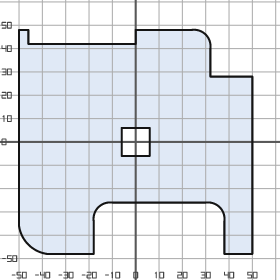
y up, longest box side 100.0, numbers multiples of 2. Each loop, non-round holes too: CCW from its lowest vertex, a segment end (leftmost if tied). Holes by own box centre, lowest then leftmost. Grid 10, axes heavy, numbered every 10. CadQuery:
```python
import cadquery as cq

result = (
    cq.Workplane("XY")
    .moveTo(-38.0, -48.0)
    .lineTo(-18.0, -48.0)
    .lineTo(-18.0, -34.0)
    .threePointArc((-16.0, -28.0), (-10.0, -26.0))
    .lineTo(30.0, -26.0)
    .threePointArc((36.0, -28.0), (38.0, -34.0))
    .lineTo(38.0, -48.0)
    .lineTo(50.0, -48.0)
    .lineTo(50.0, 28.0)
    .lineTo(32.0, 28.0)
    .lineTo(32.0, 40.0)
    .threePointArc((30.0, 46.0), (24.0, 48.0))
    .lineTo(0.0, 48.0)
    .lineTo(0.0, 42.0)
    .lineTo(-46.0, 42.0)
    .lineTo(-46.0, 48.0)
    .lineTo(-50.0, 48.0)
    .lineTo(-50.0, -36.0)
    .threePointArc((-46.0, -44.0), (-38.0, -48.0))
    .close()
    .moveTo(-6.0, -6.0)
    .lineTo(6.0, -6.0)
    .lineTo(6.0, 6.0)
    .lineTo(-6.0, 6.0)
    .close()
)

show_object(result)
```